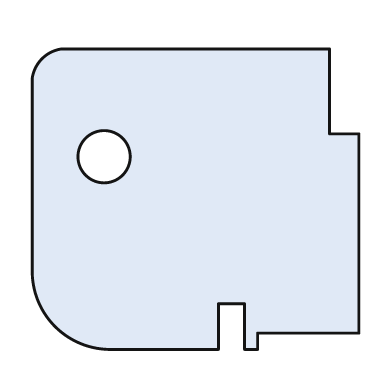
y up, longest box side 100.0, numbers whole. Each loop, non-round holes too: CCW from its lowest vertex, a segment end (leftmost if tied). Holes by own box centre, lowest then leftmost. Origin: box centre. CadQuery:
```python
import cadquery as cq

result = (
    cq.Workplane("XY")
    .moveTo(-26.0, -46.0)
    .lineTo(7.0, -46.0)
    .lineTo(7.0, -32.0)
    .lineTo(15.0, -32.0)
    .lineTo(15.0, -46.0)
    .lineTo(19.0, -46.0)
    .lineTo(19.0, -41.0)
    .lineTo(50.0, -41.0)
    .lineTo(50.0, 20.0)
    .lineTo(41.0, 20.0)
    .lineTo(41.0, 46.0)
    .lineTo(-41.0, 46.0)
    .threePointArc((-47.0, 43.0), (-50.0, 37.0))
    .lineTo(-50.0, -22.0)
    .threePointArc((-43.0, -39.0), (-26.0, -46.0))
    .close()
    .moveTo(-28.0, 13.0)
    .circle(8.0)
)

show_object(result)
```